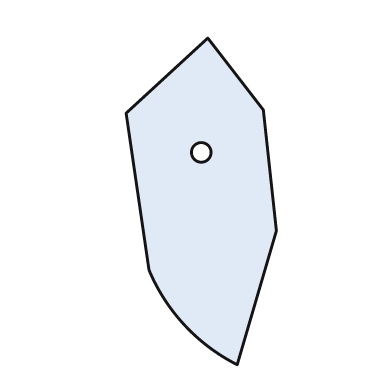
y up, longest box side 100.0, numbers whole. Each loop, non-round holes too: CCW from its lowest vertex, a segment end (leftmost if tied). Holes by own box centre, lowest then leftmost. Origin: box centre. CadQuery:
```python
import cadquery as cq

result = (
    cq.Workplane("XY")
    .moveTo(11.0, -50.0)
    .lineTo(23.0, -9.0)
    .lineTo(19.0, 28.0)
    .lineTo(2.0, 50.0)
    .lineTo(-23.0, 27.0)
    .lineTo(-16.0, -21.0)
    .threePointArc((-5.0, -38.0), (11.0, -50.0))
    .close()
    .moveTo(0.0, 15.0)
    .circle(3.0)
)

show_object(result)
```